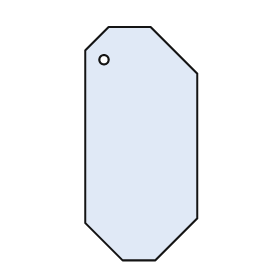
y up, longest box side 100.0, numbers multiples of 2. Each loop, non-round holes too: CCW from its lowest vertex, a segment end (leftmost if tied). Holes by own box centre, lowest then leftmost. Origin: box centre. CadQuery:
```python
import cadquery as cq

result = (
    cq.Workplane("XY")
    .moveTo(-8.0, -50.0)
    .lineTo(6.0, -50.0)
    .lineTo(24.0, -32.0)
    .lineTo(24.0, 30.0)
    .lineTo(4.0, 50.0)
    .lineTo(-14.0, 50.0)
    .lineTo(-24.0, 40.0)
    .lineTo(-24.0, -34.0)
    .close()
    .moveTo(-16.0, 36.0)
    .circle(2.0)
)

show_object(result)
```